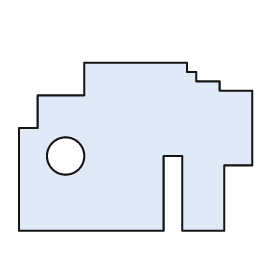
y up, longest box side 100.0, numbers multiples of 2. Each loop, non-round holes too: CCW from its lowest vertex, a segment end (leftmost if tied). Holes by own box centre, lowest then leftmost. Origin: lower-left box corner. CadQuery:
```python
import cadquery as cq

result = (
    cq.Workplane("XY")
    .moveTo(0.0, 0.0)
    .lineTo(62.0, 0.0)
    .lineTo(62.0, 32.0)
    .lineTo(70.0, 32.0)
    .lineTo(70.0, 0.0)
    .lineTo(88.0, 0.0)
    .lineTo(88.0, 28.0)
    .lineTo(100.0, 28.0)
    .lineTo(100.0, 60.0)
    .lineTo(86.0, 60.0)
    .lineTo(86.0, 64.0)
    .lineTo(76.0, 64.0)
    .lineTo(76.0, 68.0)
    .lineTo(72.0, 68.0)
    .lineTo(72.0, 72.0)
    .lineTo(28.0, 72.0)
    .lineTo(28.0, 58.0)
    .lineTo(8.0, 58.0)
    .lineTo(8.0, 44.0)
    .lineTo(0.0, 44.0)
    .close()
    .moveTo(20.0, 32.0)
    .circle(8.0)
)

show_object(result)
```